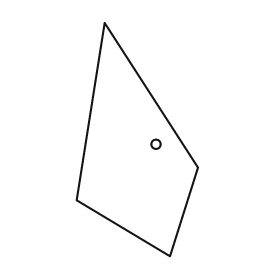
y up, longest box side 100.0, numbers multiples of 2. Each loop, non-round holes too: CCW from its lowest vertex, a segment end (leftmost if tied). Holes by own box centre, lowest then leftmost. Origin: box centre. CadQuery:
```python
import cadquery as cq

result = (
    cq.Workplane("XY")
    .moveTo(14.0, -50.0)
    .lineTo(26.0, -12.0)
    .lineTo(-14.0, 50.0)
    .lineTo(-26.0, -26.0)
    .close()
    .moveTo(8.0, -2.0)
    .circle(2.0)
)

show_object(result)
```